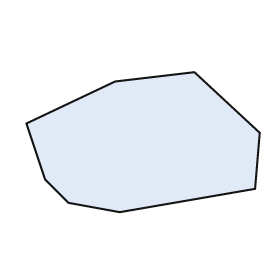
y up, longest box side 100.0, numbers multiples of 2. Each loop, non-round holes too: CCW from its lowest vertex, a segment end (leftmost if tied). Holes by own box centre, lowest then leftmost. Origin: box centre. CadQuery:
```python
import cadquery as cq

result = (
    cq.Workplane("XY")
    .moveTo(-10.0, -30.0)
    .lineTo(48.0, -20.0)
    .lineTo(50.0, 4.0)
    .lineTo(22.0, 30.0)
    .lineTo(-12.0, 26.0)
    .lineTo(-50.0, 8.0)
    .lineTo(-42.0, -16.0)
    .lineTo(-32.0, -26.0)
    .close()
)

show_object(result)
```